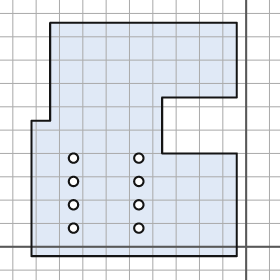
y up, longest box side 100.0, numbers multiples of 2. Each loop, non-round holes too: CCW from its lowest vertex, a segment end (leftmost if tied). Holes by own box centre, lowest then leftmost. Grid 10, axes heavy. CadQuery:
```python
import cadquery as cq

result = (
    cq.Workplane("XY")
    .moveTo(-92.0, -4.0)
    .lineTo(-4.0, -4.0)
    .lineTo(-4.0, 40.0)
    .lineTo(-36.0, 40.0)
    .lineTo(-36.0, 64.0)
    .lineTo(-4.0, 64.0)
    .lineTo(-4.0, 96.0)
    .lineTo(-84.0, 96.0)
    .lineTo(-84.0, 54.0)
    .lineTo(-92.0, 54.0)
    .close()
    .moveTo(-74.0, 8.0)
    .circle(2.0)
    .moveTo(-46.0, 8.0)
    .circle(2.0)
    .moveTo(-74.0, 18.0)
    .circle(2.0)
    .moveTo(-46.0, 18.0)
    .circle(2.0)
    .moveTo(-74.0, 28.0)
    .circle(2.0)
    .moveTo(-46.0, 28.0)
    .circle(2.0)
    .moveTo(-74.0, 38.0)
    .circle(2.0)
    .moveTo(-46.0, 38.0)
    .circle(2.0)
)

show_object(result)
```